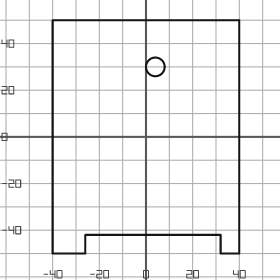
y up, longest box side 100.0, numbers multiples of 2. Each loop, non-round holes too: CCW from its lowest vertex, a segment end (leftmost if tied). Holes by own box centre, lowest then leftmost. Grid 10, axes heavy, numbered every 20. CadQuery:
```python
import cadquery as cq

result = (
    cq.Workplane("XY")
    .moveTo(-40.0, -50.0)
    .lineTo(-26.0, -50.0)
    .lineTo(-26.0, -42.0)
    .lineTo(32.0, -42.0)
    .lineTo(32.0, -50.0)
    .lineTo(40.0, -50.0)
    .lineTo(40.0, 50.0)
    .lineTo(-40.0, 50.0)
    .close()
    .moveTo(4.0, 30.0)
    .circle(4.0)
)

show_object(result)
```